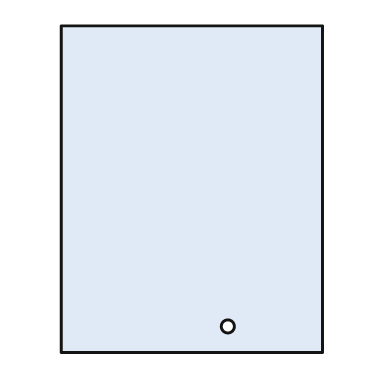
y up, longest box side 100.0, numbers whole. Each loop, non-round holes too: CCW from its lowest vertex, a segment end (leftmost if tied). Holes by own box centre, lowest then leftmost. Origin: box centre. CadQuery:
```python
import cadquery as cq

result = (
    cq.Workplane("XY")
    .moveTo(-40.0, -50.0)
    .lineTo(40.0, -50.0)
    .lineTo(40.0, 50.0)
    .lineTo(-40.0, 50.0)
    .close()
    .moveTo(11.0, -42.0)
    .circle(2.0)
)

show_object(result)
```